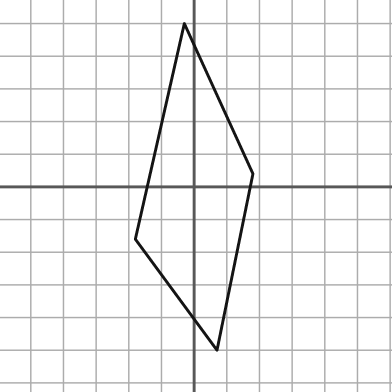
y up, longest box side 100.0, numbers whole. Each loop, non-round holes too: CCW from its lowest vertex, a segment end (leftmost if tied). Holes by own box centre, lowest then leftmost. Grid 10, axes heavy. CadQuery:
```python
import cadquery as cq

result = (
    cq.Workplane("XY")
    .moveTo(7.0, -50.0)
    .lineTo(18.0, 4.0)
    .lineTo(-3.0, 50.0)
    .lineTo(-18.0, -16.0)
    .close()
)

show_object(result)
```